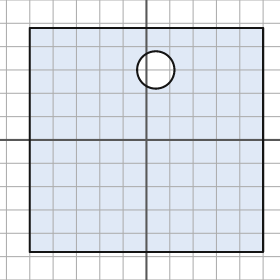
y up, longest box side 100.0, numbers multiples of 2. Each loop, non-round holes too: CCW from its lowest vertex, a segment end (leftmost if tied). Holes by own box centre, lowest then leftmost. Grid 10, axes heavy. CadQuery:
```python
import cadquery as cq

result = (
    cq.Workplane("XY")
    .moveTo(-50.0, -48.0)
    .lineTo(50.0, -48.0)
    .lineTo(50.0, 48.0)
    .lineTo(-50.0, 48.0)
    .close()
    .moveTo(4.0, 30.0)
    .circle(8.0)
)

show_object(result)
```